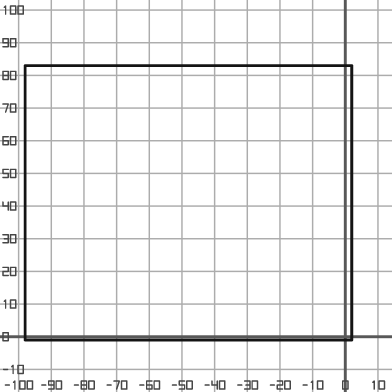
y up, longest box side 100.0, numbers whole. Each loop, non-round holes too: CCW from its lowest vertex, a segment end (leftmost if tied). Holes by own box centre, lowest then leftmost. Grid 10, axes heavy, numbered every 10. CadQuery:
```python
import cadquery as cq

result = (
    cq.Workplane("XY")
    .moveTo(-98.0, -1.0)
    .lineTo(2.0, -1.0)
    .lineTo(2.0, 83.0)
    .lineTo(-98.0, 83.0)
    .close()
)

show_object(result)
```